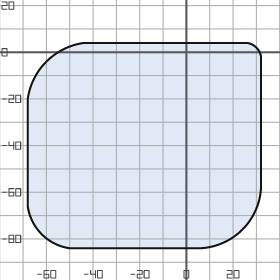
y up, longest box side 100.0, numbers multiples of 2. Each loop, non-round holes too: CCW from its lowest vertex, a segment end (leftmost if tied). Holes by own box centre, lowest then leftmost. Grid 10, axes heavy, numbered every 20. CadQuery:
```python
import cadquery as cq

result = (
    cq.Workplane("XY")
    .moveTo(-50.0, -84.0)
    .lineTo(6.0, -84.0)
    .threePointArc((24.0, -76.0), (32.0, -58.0))
    .lineTo(32.0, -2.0)
    .threePointArc((30.0, 2.0), (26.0, 4.0))
    .lineTo(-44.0, 4.0)
    .threePointArc((-60.0, -4.0), (-68.0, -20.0))
    .lineTo(-68.0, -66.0)
    .threePointArc((-62.0, -78.0), (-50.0, -84.0))
    .close()
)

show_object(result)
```